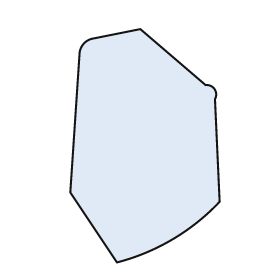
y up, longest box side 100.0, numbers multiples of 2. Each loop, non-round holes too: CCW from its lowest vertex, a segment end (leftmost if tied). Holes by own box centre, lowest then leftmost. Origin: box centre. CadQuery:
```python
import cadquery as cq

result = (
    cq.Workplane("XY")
    .moveTo(-12.0, -50.0)
    .threePointArc((12.0, -40.0), (32.0, -24.0))
    .lineTo(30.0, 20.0)
    .threePointArc((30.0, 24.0), (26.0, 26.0))
    .lineTo(-2.0, 50.0)
    .lineTo(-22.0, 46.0)
    .threePointArc((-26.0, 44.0), (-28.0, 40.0))
    .lineTo(-32.0, -20.0)
    .close()
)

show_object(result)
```